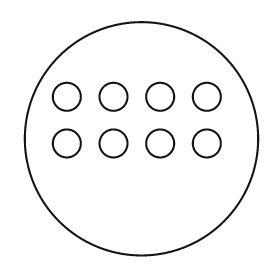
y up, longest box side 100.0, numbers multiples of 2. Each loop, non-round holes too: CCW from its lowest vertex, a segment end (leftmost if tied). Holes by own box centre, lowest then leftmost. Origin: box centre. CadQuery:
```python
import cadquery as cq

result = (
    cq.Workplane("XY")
    .moveTo(0.0, 0.0)
    .circle(50.0)
    .moveTo(-32.0, -2.0)
    .circle(6.0)
    .moveTo(-12.0, -2.0)
    .circle(6.0)
    .moveTo(8.0, -2.0)
    .circle(6.0)
    .moveTo(28.0, -2.0)
    .circle(6.0)
    .moveTo(-32.0, 18.0)
    .circle(6.0)
    .moveTo(-12.0, 18.0)
    .circle(6.0)
    .moveTo(8.0, 18.0)
    .circle(6.0)
    .moveTo(28.0, 18.0)
    .circle(6.0)
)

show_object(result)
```